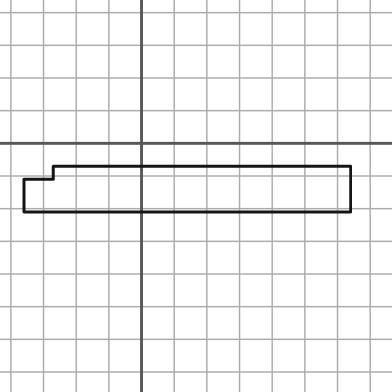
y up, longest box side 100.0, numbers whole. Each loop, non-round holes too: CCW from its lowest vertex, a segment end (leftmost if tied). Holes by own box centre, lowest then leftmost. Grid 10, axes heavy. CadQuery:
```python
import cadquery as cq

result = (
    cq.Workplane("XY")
    .moveTo(-36.0, -21.0)
    .lineTo(64.0, -21.0)
    .lineTo(64.0, -7.0)
    .lineTo(-27.0, -7.0)
    .lineTo(-27.0, -11.0)
    .lineTo(-36.0, -11.0)
    .close()
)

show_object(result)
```